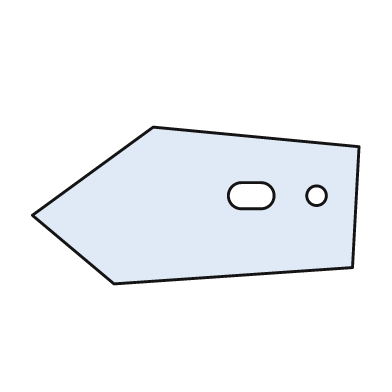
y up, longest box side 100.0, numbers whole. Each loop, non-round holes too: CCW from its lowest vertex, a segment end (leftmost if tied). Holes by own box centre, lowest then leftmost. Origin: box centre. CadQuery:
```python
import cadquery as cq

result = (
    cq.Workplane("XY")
    .moveTo(-25.0, -24.0)
    .lineTo(48.0, -19.0)
    .lineTo(50.0, 18.0)
    .lineTo(-13.0, 24.0)
    .lineTo(-50.0, -3.0)
    .close()
    .moveTo(14.0, -1.0)
    .lineTo(20.0, -1.0)
    .threePointArc((24.0, 3.0), (20.0, 7.0))
    .lineTo(14.0, 7.0)
    .threePointArc((10.0, 3.0), (14.0, -1.0))
    .close()
    .moveTo(37.0, 3.0)
    .circle(3.0)
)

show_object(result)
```